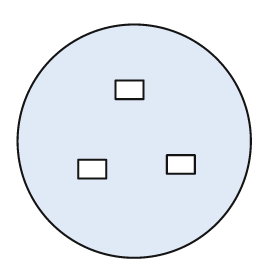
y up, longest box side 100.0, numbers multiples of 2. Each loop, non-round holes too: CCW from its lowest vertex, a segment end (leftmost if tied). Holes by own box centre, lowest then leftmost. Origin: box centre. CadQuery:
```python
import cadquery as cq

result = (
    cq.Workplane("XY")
    .moveTo(0.0, 0.0)
    .circle(50.0)
    .moveTo(-24.0, -16.0)
    .lineTo(-12.0, -16.0)
    .lineTo(-12.0, -8.0)
    .lineTo(-24.0, -8.0)
    .close()
    .moveTo(14.0, -14.0)
    .lineTo(26.0, -14.0)
    .lineTo(26.0, -6.0)
    .lineTo(14.0, -6.0)
    .close()
    .moveTo(-8.0, 18.0)
    .lineTo(4.0, 18.0)
    .lineTo(4.0, 26.0)
    .lineTo(-8.0, 26.0)
    .close()
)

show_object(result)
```